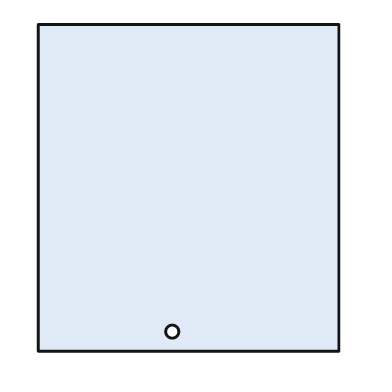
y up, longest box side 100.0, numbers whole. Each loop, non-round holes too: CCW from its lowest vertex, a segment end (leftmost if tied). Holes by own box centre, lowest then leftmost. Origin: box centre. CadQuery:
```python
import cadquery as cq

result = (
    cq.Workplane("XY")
    .moveTo(-46.0, -50.0)
    .lineTo(46.0, -50.0)
    .lineTo(46.0, 50.0)
    .lineTo(-46.0, 50.0)
    .close()
    .moveTo(-5.0, -44.0)
    .circle(2.0)
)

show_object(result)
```